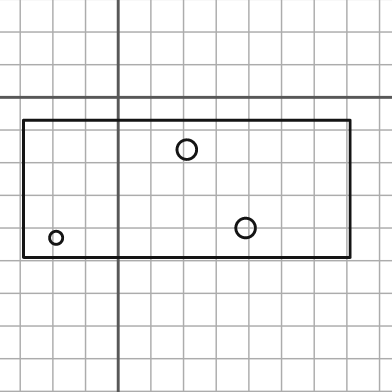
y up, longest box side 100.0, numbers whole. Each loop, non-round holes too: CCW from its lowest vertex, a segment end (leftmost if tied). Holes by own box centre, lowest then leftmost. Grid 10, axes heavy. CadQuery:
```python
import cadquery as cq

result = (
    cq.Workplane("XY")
    .moveTo(-29.0, -49.0)
    .lineTo(71.0, -49.0)
    .lineTo(71.0, -7.0)
    .lineTo(-29.0, -7.0)
    .close()
    .moveTo(-19.0, -43.0)
    .circle(2.0)
    .moveTo(39.0, -40.0)
    .circle(3.0)
    .moveTo(21.0, -16.0)
    .circle(3.0)
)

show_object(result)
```